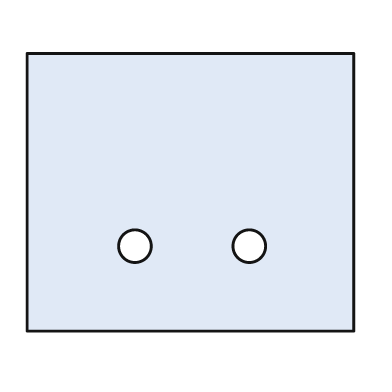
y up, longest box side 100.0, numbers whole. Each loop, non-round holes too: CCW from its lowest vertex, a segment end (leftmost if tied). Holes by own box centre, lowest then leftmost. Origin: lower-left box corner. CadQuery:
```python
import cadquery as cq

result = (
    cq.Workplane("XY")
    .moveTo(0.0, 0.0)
    .lineTo(100.0, 0.0)
    .lineTo(100.0, 85.0)
    .lineTo(0.0, 85.0)
    .close()
    .moveTo(33.0, 26.0)
    .circle(5.0)
    .moveTo(68.0, 26.0)
    .circle(5.0)
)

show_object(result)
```